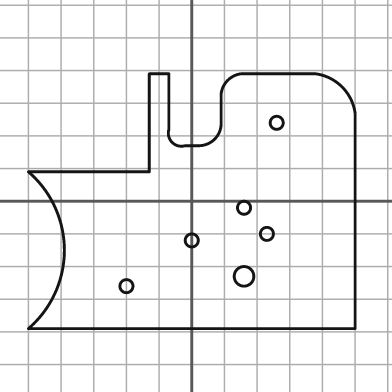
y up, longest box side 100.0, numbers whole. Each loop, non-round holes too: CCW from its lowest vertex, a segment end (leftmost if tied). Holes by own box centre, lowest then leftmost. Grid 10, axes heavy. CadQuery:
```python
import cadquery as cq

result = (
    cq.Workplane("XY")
    .moveTo(-50.0, -39.0)
    .lineTo(50.0, -39.0)
    .lineTo(50.0, 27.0)
    .threePointArc((46.0, 35.0), (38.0, 39.0))
    .lineTo(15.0, 39.0)
    .threePointArc((11.0, 37.0), (9.0, 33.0))
    .lineTo(9.0, 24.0)
    .threePointArc((7.0, 19.0), (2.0, 17.0))
    .lineTo(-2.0, 17.0)
    .threePointArc((-6.0, 18.0), (-7.0, 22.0))
    .lineTo(-7.0, 39.0)
    .lineTo(-13.0, 39.0)
    .lineTo(-13.0, 9.0)
    .lineTo(-50.0, 9.0)
    .threePointArc((-39.0, -15.0), (-50.0, -39.0))
    .close()
    .moveTo(-20.0, -26.0)
    .circle(2.0)
    .moveTo(16.0, -23.0)
    .circle(3.0)
    .moveTo(0.0, -12.0)
    .circle(2.0)
    .moveTo(23.0, -10.0)
    .circle(2.0)
    .moveTo(16.0, -2.0)
    .circle(2.0)
    .moveTo(26.0, 24.0)
    .circle(2.0)
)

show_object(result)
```